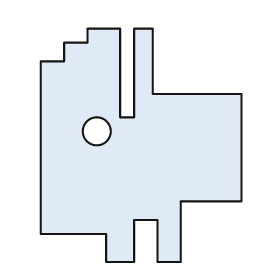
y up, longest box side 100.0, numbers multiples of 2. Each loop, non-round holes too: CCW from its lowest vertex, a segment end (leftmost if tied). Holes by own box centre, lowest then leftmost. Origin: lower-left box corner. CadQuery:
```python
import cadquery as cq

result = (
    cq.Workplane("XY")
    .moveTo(28.0, 0.0)
    .lineTo(40.0, 0.0)
    .lineTo(40.0, 18.0)
    .lineTo(50.0, 18.0)
    .lineTo(50.0, 0.0)
    .lineTo(60.0, 0.0)
    .lineTo(60.0, 26.0)
    .lineTo(86.0, 26.0)
    .lineTo(86.0, 72.0)
    .lineTo(48.0, 72.0)
    .lineTo(48.0, 100.0)
    .lineTo(40.0, 100.0)
    .lineTo(40.0, 62.0)
    .lineTo(34.0, 62.0)
    .lineTo(34.0, 100.0)
    .lineTo(20.0, 100.0)
    .lineTo(20.0, 94.0)
    .lineTo(10.0, 94.0)
    .lineTo(10.0, 86.0)
    .lineTo(0.0, 86.0)
    .lineTo(0.0, 12.0)
    .lineTo(28.0, 12.0)
    .close()
    .moveTo(24.0, 56.0)
    .circle(6.0)
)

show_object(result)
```